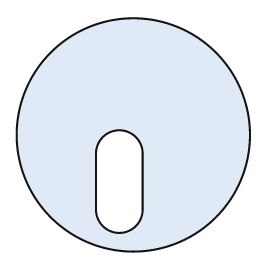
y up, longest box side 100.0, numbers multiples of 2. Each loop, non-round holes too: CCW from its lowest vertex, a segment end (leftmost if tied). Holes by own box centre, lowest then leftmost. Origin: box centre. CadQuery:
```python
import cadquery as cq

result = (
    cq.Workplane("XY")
    .moveTo(0.0, 0.0)
    .circle(50.0)
    .moveTo(-16.0, -32.0)
    .threePointArc((-6.0, -42.0), (4.0, -32.0))
    .lineTo(4.0, -8.0)
    .threePointArc((-6.0, 2.0), (-16.0, -8.0))
    .close()
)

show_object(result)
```